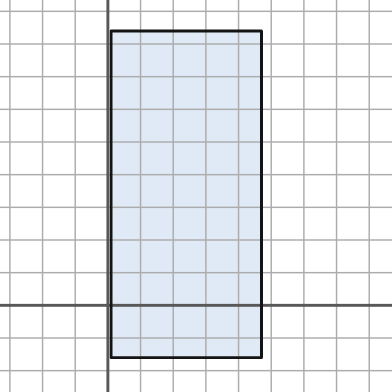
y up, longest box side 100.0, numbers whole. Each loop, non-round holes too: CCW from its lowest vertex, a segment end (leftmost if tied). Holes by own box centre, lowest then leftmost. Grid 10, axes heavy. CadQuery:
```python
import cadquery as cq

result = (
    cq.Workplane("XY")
    .moveTo(1.0, -16.0)
    .lineTo(47.0, -16.0)
    .lineTo(47.0, 84.0)
    .lineTo(1.0, 84.0)
    .close()
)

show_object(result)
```